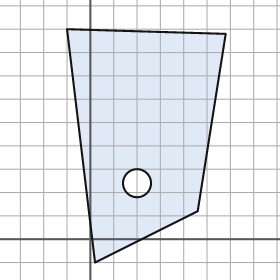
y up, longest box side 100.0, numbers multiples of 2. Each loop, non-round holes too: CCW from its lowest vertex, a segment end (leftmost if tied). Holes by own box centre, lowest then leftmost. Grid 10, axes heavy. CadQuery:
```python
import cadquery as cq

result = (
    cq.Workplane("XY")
    .moveTo(2.0, -10.0)
    .lineTo(46.0, 12.0)
    .lineTo(58.0, 88.0)
    .lineTo(-10.0, 90.0)
    .close()
    .moveTo(20.0, 24.0)
    .circle(6.0)
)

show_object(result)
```